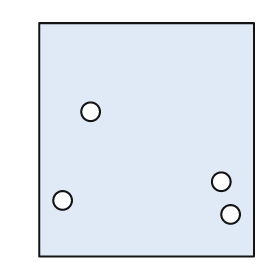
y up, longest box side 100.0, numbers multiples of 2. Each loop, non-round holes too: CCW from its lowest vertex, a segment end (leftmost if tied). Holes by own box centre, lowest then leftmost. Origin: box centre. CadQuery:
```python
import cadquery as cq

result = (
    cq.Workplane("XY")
    .moveTo(-46.0, -50.0)
    .lineTo(46.0, -50.0)
    .lineTo(46.0, 50.0)
    .lineTo(-46.0, 50.0)
    .close()
    .moveTo(36.0, -32.0)
    .circle(4.0)
    .moveTo(-36.0, -26.0)
    .circle(4.0)
    .moveTo(32.0, -18.0)
    .circle(4.0)
    .moveTo(-24.0, 12.0)
    .circle(4.0)
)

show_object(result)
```